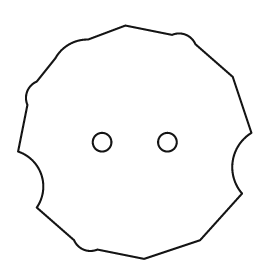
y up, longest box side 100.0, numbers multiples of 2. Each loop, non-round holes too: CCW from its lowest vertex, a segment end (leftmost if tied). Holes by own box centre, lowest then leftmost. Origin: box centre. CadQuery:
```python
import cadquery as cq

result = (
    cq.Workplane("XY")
    .moveTo(4.0, -50.0)
    .lineTo(28.0, -42.0)
    .lineTo(46.0, -22.0)
    .threePointArc((42.0, -8.0), (50.0, 4.0))
    .lineTo(42.0, 28.0)
    .lineTo(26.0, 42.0)
    .threePointArc((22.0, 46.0), (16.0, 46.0))
    .lineTo(-4.0, 50.0)
    .lineTo(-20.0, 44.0)
    .threePointArc((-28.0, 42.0), (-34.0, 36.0))
    .lineTo(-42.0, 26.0)
    .threePointArc((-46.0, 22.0), (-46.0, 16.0))
    .lineTo(-50.0, -4.0)
    .threePointArc((-40.0, -14.0), (-42.0, -28.0))
    .lineTo(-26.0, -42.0)
    .threePointArc((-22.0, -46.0), (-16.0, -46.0))
    .close()
    .moveTo(-14.0, 0.0)
    .circle(4.0)
    .moveTo(14.0, 0.0)
    .circle(4.0)
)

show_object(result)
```